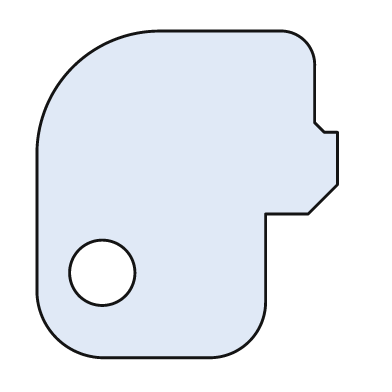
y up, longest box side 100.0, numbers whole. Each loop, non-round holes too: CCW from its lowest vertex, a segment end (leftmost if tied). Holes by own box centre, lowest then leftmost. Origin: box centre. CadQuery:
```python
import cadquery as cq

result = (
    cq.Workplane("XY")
    .moveTo(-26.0, -50.0)
    .lineTo(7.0, -50.0)
    .threePointArc((19.0, -45.0), (24.0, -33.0))
    .lineTo(24.0, -6.0)
    .lineTo(37.0, -6.0)
    .lineTo(46.0, 3.0)
    .lineTo(46.0, 19.0)
    .lineTo(42.0, 19.0)
    .lineTo(39.0, 22.0)
    .lineTo(39.0, 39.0)
    .threePointArc((36.0, 47.0), (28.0, 50.0))
    .lineTo(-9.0, 50.0)
    .threePointArc((-35.0, 39.0), (-46.0, 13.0))
    .lineTo(-46.0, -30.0)
    .threePointArc((-40.0, -44.0), (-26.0, -50.0))
    .close()
    .moveTo(-26.0, -24.0)
    .circle(10.0)
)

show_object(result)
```